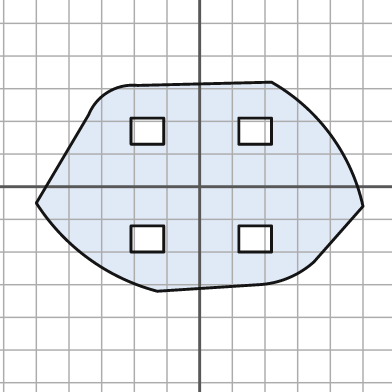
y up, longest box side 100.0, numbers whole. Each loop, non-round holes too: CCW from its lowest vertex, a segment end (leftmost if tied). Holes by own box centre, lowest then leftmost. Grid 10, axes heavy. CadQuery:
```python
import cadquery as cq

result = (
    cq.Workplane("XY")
    .moveTo(-13.0, -32.0)
    .lineTo(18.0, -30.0)
    .threePointArc((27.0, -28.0), (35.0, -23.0))
    .lineTo(50.0, -6.0)
    .threePointArc((40.0, 16.0), (22.0, 32.0))
    .lineTo(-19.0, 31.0)
    .threePointArc((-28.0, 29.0), (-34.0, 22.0))
    .lineTo(-50.0, -5.0)
    .threePointArc((-34.0, -22.0), (-13.0, -32.0))
    .close()
    .moveTo(-21.0, -20.0)
    .lineTo(-11.0, -20.0)
    .lineTo(-11.0, -12.0)
    .lineTo(-21.0, -12.0)
    .close()
    .moveTo(12.0, -20.0)
    .lineTo(22.0, -20.0)
    .lineTo(22.0, -12.0)
    .lineTo(12.0, -12.0)
    .close()
    .moveTo(-21.0, 13.0)
    .lineTo(-11.0, 13.0)
    .lineTo(-11.0, 21.0)
    .lineTo(-21.0, 21.0)
    .close()
    .moveTo(12.0, 13.0)
    .lineTo(22.0, 13.0)
    .lineTo(22.0, 21.0)
    .lineTo(12.0, 21.0)
    .close()
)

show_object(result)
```